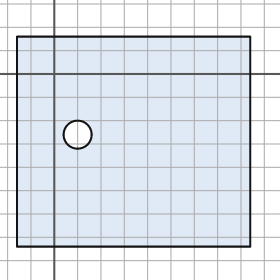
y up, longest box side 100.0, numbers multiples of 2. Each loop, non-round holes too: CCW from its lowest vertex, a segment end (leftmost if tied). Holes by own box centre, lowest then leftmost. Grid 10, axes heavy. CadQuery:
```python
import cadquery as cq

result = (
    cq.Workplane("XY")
    .moveTo(-16.0, -74.0)
    .lineTo(84.0, -74.0)
    .lineTo(84.0, 16.0)
    .lineTo(-16.0, 16.0)
    .close()
    .moveTo(10.0, -26.0)
    .circle(6.0)
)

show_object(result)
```